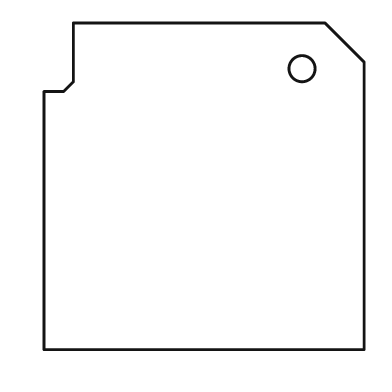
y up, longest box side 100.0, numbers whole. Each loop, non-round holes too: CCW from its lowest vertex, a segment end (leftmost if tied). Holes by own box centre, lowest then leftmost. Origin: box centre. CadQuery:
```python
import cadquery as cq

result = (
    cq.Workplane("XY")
    .moveTo(-49.0, -50.0)
    .lineTo(49.0, -50.0)
    .lineTo(49.0, 38.0)
    .lineTo(37.0, 50.0)
    .lineTo(-40.0, 50.0)
    .lineTo(-40.0, 32.0)
    .lineTo(-43.0, 29.0)
    .lineTo(-49.0, 29.0)
    .close()
    .moveTo(30.0, 36.0)
    .circle(4.0)
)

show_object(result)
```